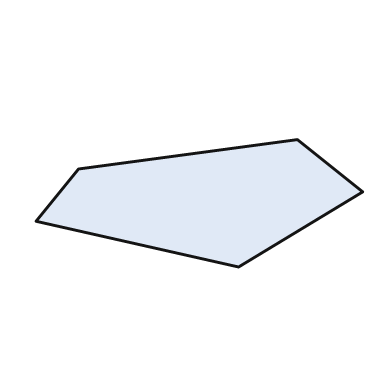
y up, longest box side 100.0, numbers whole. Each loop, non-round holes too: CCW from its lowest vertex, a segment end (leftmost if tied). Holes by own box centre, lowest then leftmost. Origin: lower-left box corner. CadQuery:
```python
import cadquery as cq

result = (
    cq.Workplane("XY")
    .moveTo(62.0, 0.0)
    .lineTo(100.0, 23.0)
    .lineTo(80.0, 39.0)
    .lineTo(13.0, 30.0)
    .lineTo(0.0, 14.0)
    .close()
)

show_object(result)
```